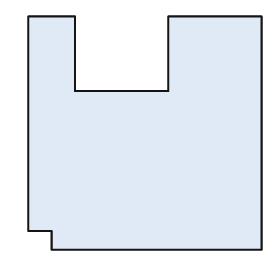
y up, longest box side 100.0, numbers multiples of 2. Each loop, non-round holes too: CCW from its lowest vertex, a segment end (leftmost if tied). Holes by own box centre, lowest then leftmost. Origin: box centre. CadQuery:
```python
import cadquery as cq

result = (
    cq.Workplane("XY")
    .moveTo(-40.0, -50.0)
    .lineTo(50.0, -50.0)
    .lineTo(50.0, 50.0)
    .lineTo(10.0, 50.0)
    .lineTo(10.0, 18.0)
    .lineTo(-30.0, 18.0)
    .lineTo(-30.0, 50.0)
    .lineTo(-50.0, 50.0)
    .lineTo(-50.0, -42.0)
    .lineTo(-40.0, -42.0)
    .close()
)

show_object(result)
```